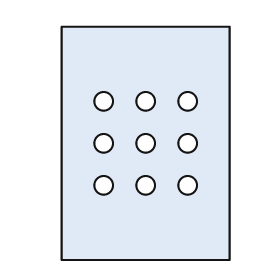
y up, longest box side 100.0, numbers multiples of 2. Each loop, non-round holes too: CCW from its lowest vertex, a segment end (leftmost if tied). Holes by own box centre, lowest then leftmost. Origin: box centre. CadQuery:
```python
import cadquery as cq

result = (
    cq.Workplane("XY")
    .moveTo(-36.0, -50.0)
    .lineTo(36.0, -50.0)
    .lineTo(36.0, 50.0)
    .lineTo(-36.0, 50.0)
    .close()
    .moveTo(-18.0, -18.0)
    .circle(4.0)
    .moveTo(0.0, -18.0)
    .circle(4.0)
    .moveTo(18.0, -18.0)
    .circle(4.0)
    .moveTo(-18.0, 0.0)
    .circle(4.0)
    .moveTo(0.0, 0.0)
    .circle(4.0)
    .moveTo(18.0, 0.0)
    .circle(4.0)
    .moveTo(-18.0, 18.0)
    .circle(4.0)
    .moveTo(0.0, 18.0)
    .circle(4.0)
    .moveTo(18.0, 18.0)
    .circle(4.0)
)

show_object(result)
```